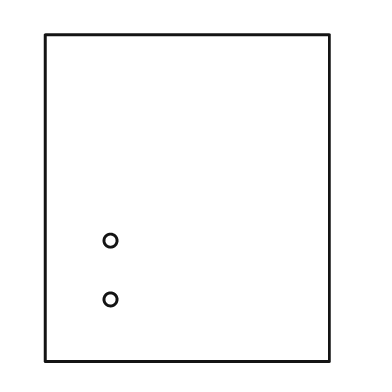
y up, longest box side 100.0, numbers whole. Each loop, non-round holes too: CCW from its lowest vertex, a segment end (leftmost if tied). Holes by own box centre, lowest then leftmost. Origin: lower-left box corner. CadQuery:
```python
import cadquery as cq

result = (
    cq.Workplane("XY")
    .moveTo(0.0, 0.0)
    .lineTo(87.0, 0.0)
    .lineTo(87.0, 100.0)
    .lineTo(0.0, 100.0)
    .close()
    .moveTo(20.0, 19.0)
    .circle(2.0)
    .moveTo(20.0, 37.0)
    .circle(2.0)
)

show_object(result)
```